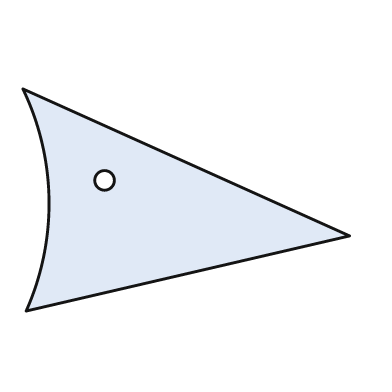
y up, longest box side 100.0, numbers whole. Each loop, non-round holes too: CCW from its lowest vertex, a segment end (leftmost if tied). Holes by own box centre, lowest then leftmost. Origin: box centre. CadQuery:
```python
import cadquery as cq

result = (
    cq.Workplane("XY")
    .moveTo(-49.0, -34.0)
    .lineTo(50.0, -11.0)
    .lineTo(-50.0, 34.0)
    .threePointArc((-42.0, 0.0), (-49.0, -34.0))
    .close()
    .moveTo(-25.0, 6.0)
    .circle(3.0)
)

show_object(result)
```